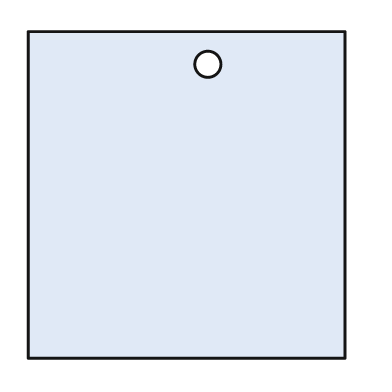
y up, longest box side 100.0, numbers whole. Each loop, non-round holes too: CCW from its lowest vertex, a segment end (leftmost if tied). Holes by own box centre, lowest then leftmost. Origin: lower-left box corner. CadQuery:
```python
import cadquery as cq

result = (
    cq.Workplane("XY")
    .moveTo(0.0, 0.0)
    .lineTo(97.0, 0.0)
    .lineTo(97.0, 100.0)
    .lineTo(0.0, 100.0)
    .close()
    .moveTo(55.0, 90.0)
    .circle(4.0)
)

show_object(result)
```